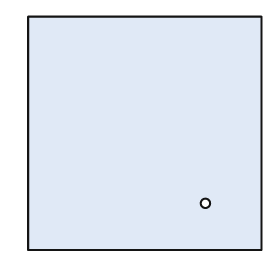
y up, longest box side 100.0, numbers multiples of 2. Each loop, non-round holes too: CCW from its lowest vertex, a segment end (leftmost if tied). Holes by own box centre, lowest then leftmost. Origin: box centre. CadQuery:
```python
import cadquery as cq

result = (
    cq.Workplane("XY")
    .moveTo(-50.0, -50.0)
    .lineTo(50.0, -50.0)
    .lineTo(50.0, 50.0)
    .lineTo(-50.0, 50.0)
    .close()
    .moveTo(26.0, -30.0)
    .circle(2.0)
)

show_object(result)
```